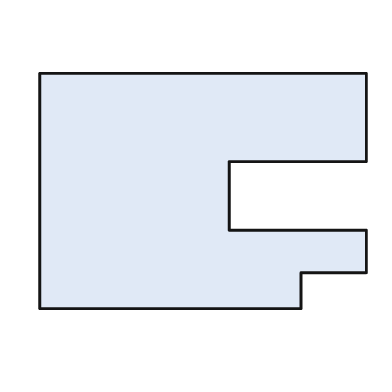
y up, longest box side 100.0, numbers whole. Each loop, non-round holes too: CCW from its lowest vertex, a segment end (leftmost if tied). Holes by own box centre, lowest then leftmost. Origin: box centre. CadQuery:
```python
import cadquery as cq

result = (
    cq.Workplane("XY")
    .moveTo(-50.0, -36.0)
    .lineTo(30.0, -36.0)
    .lineTo(30.0, -25.0)
    .lineTo(50.0, -25.0)
    .lineTo(50.0, -12.0)
    .lineTo(8.0, -12.0)
    .lineTo(8.0, 9.0)
    .lineTo(50.0, 9.0)
    .lineTo(50.0, 36.0)
    .lineTo(-50.0, 36.0)
    .close()
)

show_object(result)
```